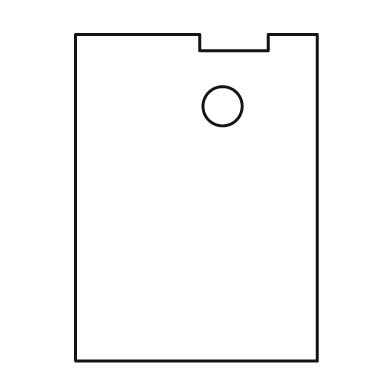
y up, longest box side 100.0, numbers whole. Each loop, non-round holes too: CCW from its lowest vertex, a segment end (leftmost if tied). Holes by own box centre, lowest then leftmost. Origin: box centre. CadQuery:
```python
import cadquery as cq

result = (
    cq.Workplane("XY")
    .moveTo(-37.0, -50.0)
    .lineTo(37.0, -50.0)
    .lineTo(37.0, 50.0)
    .lineTo(22.0, 50.0)
    .lineTo(22.0, 45.0)
    .lineTo(1.0, 45.0)
    .lineTo(1.0, 50.0)
    .lineTo(-37.0, 50.0)
    .close()
    .moveTo(8.0, 28.0)
    .circle(6.0)
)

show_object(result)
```